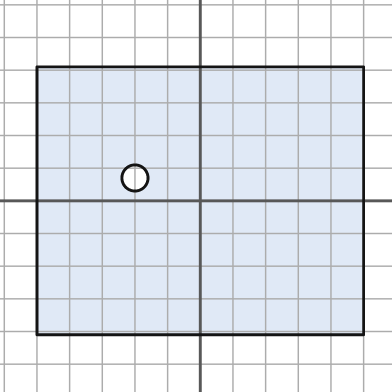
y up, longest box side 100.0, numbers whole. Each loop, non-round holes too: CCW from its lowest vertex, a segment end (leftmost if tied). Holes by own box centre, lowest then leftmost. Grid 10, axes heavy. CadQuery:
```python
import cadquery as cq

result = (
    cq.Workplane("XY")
    .moveTo(-50.0, -41.0)
    .lineTo(50.0, -41.0)
    .lineTo(50.0, 41.0)
    .lineTo(-50.0, 41.0)
    .close()
    .moveTo(-20.0, 7.0)
    .circle(4.0)
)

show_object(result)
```